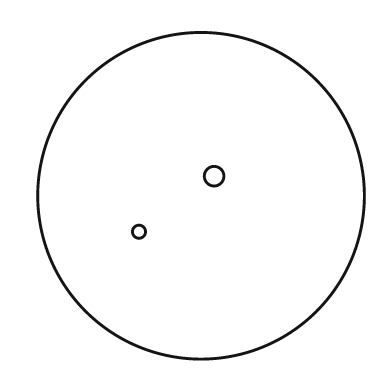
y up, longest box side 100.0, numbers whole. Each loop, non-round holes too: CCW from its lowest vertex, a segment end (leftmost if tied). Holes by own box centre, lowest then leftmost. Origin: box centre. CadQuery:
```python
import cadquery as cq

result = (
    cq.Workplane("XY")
    .moveTo(0.0, 0.0)
    .circle(50.0)
    .moveTo(-19.0, -11.0)
    .circle(2.0)
    .moveTo(4.0, 6.0)
    .circle(3.0)
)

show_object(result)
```